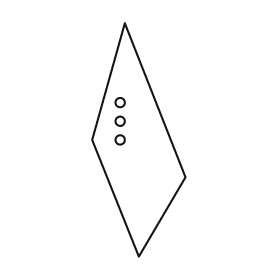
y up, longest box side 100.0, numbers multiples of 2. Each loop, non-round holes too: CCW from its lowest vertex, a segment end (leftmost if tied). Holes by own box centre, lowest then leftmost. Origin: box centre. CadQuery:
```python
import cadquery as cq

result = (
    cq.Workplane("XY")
    .moveTo(0.0, -50.0)
    .lineTo(20.0, -16.0)
    .lineTo(-6.0, 50.0)
    .lineTo(-20.0, 0.0)
    .close()
    .moveTo(-8.0, 0.0)
    .circle(2.0)
    .moveTo(-8.0, 8.0)
    .circle(2.0)
    .moveTo(-8.0, 16.0)
    .circle(2.0)
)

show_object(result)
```